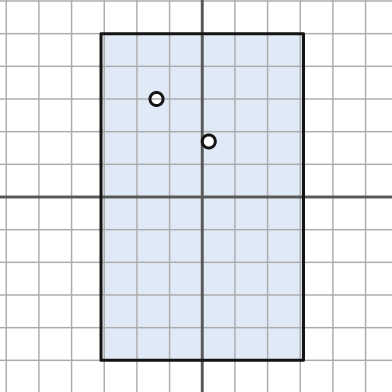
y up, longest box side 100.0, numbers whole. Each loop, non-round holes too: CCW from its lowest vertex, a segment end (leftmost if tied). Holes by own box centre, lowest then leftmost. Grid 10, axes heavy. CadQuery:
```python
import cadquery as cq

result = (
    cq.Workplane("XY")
    .moveTo(-31.0, -50.0)
    .lineTo(31.0, -50.0)
    .lineTo(31.0, 50.0)
    .lineTo(-31.0, 50.0)
    .close()
    .moveTo(2.0, 17.0)
    .circle(2.0)
    .moveTo(-14.0, 30.0)
    .circle(2.0)
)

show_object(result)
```